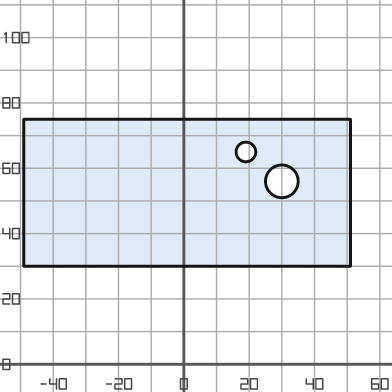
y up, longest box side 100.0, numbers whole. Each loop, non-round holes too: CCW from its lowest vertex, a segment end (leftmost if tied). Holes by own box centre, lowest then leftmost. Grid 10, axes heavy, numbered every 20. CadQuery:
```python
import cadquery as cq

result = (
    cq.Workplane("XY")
    .moveTo(-49.0, 30.0)
    .lineTo(51.0, 30.0)
    .lineTo(51.0, 75.0)
    .lineTo(-49.0, 75.0)
    .close()
    .moveTo(30.0, 56.0)
    .circle(5.0)
    .moveTo(19.0, 65.0)
    .circle(3.0)
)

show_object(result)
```